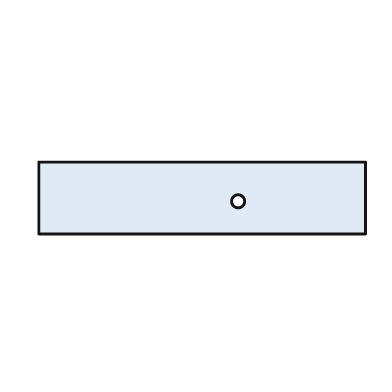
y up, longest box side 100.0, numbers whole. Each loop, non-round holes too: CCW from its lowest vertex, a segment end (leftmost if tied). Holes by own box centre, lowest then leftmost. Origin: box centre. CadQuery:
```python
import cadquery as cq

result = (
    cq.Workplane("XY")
    .moveTo(-50.0, -11.0)
    .lineTo(50.0, -11.0)
    .lineTo(50.0, 11.0)
    .lineTo(-50.0, 11.0)
    .close()
    .moveTo(11.0, -1.0)
    .circle(2.0)
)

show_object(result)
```